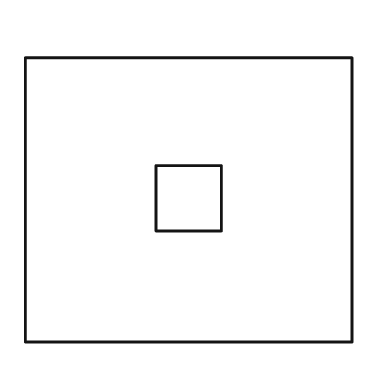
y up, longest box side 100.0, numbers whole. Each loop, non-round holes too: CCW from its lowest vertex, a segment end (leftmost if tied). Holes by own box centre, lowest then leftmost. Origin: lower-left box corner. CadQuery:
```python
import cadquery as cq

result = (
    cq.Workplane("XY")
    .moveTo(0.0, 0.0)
    .lineTo(100.0, 0.0)
    .lineTo(100.0, 87.0)
    .lineTo(0.0, 87.0)
    .close()
    .moveTo(40.0, 34.0)
    .lineTo(60.0, 34.0)
    .lineTo(60.0, 54.0)
    .lineTo(40.0, 54.0)
    .close()
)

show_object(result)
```